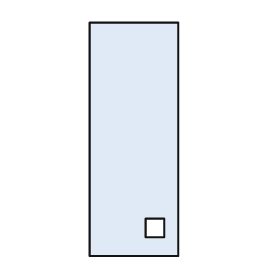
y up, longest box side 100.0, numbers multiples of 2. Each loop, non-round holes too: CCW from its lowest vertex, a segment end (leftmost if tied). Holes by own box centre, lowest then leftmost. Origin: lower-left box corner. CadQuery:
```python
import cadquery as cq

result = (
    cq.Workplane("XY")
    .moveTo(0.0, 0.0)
    .lineTo(38.0, 0.0)
    .lineTo(38.0, 100.0)
    .lineTo(0.0, 100.0)
    .close()
    .moveTo(24.0, 8.0)
    .lineTo(32.0, 8.0)
    .lineTo(32.0, 16.0)
    .lineTo(24.0, 16.0)
    .close()
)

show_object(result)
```